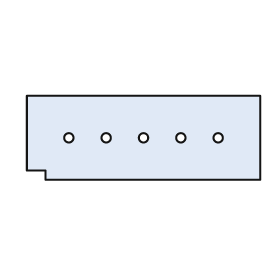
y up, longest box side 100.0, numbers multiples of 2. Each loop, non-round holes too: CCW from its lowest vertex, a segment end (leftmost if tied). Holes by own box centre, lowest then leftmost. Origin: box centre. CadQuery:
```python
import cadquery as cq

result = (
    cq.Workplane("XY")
    .moveTo(-42.0, -18.0)
    .lineTo(50.0, -18.0)
    .lineTo(50.0, 18.0)
    .lineTo(-50.0, 18.0)
    .lineTo(-50.0, -14.0)
    .lineTo(-42.0, -14.0)
    .close()
    .moveTo(-32.0, 0.0)
    .circle(2.0)
    .moveTo(-16.0, 0.0)
    .circle(2.0)
    .moveTo(0.0, 0.0)
    .circle(2.0)
    .moveTo(16.0, 0.0)
    .circle(2.0)
    .moveTo(32.0, 0.0)
    .circle(2.0)
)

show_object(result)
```